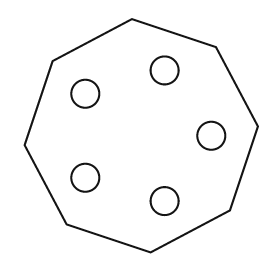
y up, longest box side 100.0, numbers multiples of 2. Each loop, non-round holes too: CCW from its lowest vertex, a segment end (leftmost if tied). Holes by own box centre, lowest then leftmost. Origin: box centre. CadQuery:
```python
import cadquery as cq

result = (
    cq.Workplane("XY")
    .moveTo(4.0, -50.0)
    .lineTo(38.0, -32.0)
    .lineTo(50.0, 4.0)
    .lineTo(32.0, 38.0)
    .lineTo(-4.0, 50.0)
    .lineTo(-38.0, 32.0)
    .lineTo(-50.0, -4.0)
    .lineTo(-32.0, -38.0)
    .close()
    .moveTo(10.0, -28.0)
    .circle(6.0)
    .moveTo(-24.0, -18.0)
    .circle(6.0)
    .moveTo(30.0, 0.0)
    .circle(6.0)
    .moveTo(-24.0, 18.0)
    .circle(6.0)
    .moveTo(10.0, 28.0)
    .circle(6.0)
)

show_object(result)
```